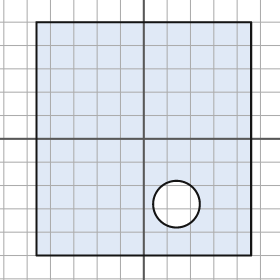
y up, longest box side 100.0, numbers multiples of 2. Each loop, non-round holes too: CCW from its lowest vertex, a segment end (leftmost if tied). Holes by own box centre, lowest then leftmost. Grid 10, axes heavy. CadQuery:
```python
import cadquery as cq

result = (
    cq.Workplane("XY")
    .moveTo(-46.0, -50.0)
    .lineTo(46.0, -50.0)
    .lineTo(46.0, 50.0)
    .lineTo(-46.0, 50.0)
    .close()
    .moveTo(14.0, -28.0)
    .circle(10.0)
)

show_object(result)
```